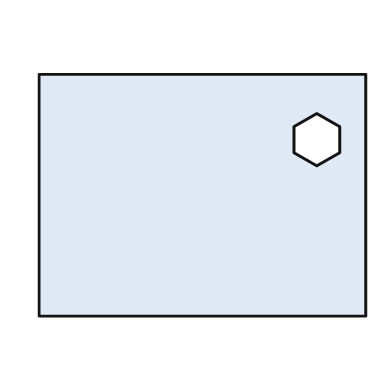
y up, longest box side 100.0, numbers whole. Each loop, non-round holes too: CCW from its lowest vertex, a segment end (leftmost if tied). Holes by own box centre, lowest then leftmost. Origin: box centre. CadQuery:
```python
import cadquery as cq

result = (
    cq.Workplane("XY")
    .moveTo(-50.0, -37.0)
    .lineTo(50.0, -37.0)
    .lineTo(50.0, 37.0)
    .lineTo(-50.0, 37.0)
    .close()
    .moveTo(35.0, 9.0)
    .lineTo(42.0, 13.0)
    .lineTo(42.0, 21.0)
    .lineTo(35.0, 25.0)
    .lineTo(28.0, 21.0)
    .lineTo(28.0, 13.0)
    .close()
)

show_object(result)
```